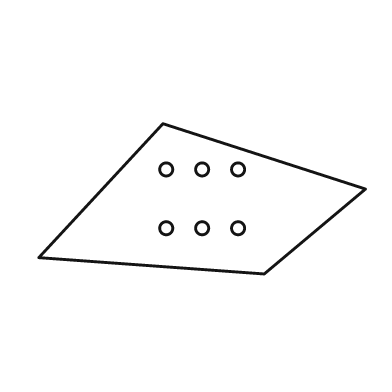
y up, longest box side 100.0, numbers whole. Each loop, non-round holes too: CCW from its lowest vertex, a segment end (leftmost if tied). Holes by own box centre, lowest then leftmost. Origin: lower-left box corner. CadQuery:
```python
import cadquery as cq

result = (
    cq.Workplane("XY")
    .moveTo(69.0, 0.0)
    .lineTo(100.0, 26.0)
    .lineTo(38.0, 46.0)
    .lineTo(0.0, 5.0)
    .close()
    .moveTo(39.0, 14.0)
    .circle(2.0)
    .moveTo(50.0, 14.0)
    .circle(2.0)
    .moveTo(61.0, 14.0)
    .circle(2.0)
    .moveTo(39.0, 32.0)
    .circle(2.0)
    .moveTo(50.0, 32.0)
    .circle(2.0)
    .moveTo(61.0, 32.0)
    .circle(2.0)
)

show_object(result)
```